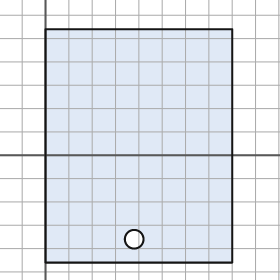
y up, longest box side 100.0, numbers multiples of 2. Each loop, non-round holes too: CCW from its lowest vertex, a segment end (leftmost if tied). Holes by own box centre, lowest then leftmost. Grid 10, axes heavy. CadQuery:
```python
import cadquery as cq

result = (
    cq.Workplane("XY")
    .moveTo(0.0, -46.0)
    .lineTo(80.0, -46.0)
    .lineTo(80.0, 54.0)
    .lineTo(0.0, 54.0)
    .close()
    .moveTo(38.0, -36.0)
    .circle(4.0)
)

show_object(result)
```